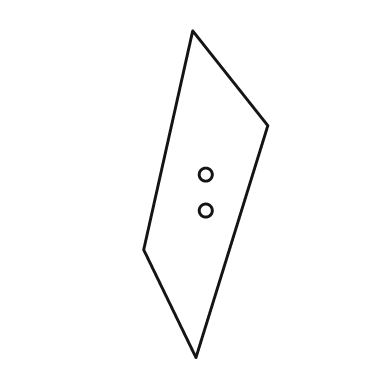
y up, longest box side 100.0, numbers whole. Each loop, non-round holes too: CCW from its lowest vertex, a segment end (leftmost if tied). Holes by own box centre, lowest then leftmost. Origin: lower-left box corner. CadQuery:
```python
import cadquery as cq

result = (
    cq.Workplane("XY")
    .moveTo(16.0, 0.0)
    .lineTo(38.0, 71.0)
    .lineTo(15.0, 100.0)
    .lineTo(0.0, 33.0)
    .close()
    .moveTo(19.0, 45.0)
    .circle(2.0)
    .moveTo(19.0, 56.0)
    .circle(2.0)
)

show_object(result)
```